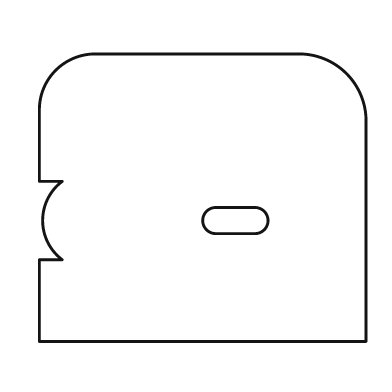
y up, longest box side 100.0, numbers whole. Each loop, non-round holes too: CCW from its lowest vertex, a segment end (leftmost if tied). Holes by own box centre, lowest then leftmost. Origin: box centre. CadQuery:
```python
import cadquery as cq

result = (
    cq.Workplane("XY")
    .moveTo(-50.0, -44.0)
    .lineTo(50.0, -44.0)
    .lineTo(50.0, 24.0)
    .threePointArc((44.0, 38.0), (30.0, 44.0))
    .lineTo(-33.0, 44.0)
    .threePointArc((-45.0, 39.0), (-50.0, 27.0))
    .lineTo(-50.0, 5.0)
    .lineTo(-43.0, 5.0)
    .threePointArc((-49.0, -7.0), (-43.0, -19.0))
    .lineTo(-50.0, -19.0)
    .close()
    .moveTo(4.0, -11.0)
    .lineTo(16.0, -11.0)
    .threePointArc((20.0, -7.0), (16.0, -3.0))
    .lineTo(4.0, -3.0)
    .threePointArc((0.0, -7.0), (4.0, -11.0))
    .close()
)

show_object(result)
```